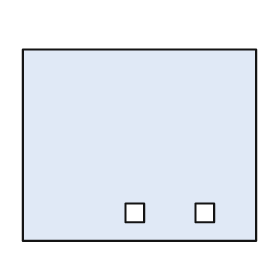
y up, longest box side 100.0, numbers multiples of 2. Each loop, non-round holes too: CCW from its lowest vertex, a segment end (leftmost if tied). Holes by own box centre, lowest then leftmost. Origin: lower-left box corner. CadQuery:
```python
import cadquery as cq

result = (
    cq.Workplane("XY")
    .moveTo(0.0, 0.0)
    .lineTo(100.0, 0.0)
    .lineTo(100.0, 82.0)
    .lineTo(0.0, 82.0)
    .close()
    .moveTo(44.0, 8.0)
    .lineTo(52.0, 8.0)
    .lineTo(52.0, 16.0)
    .lineTo(44.0, 16.0)
    .close()
    .moveTo(74.0, 8.0)
    .lineTo(82.0, 8.0)
    .lineTo(82.0, 16.0)
    .lineTo(74.0, 16.0)
    .close()
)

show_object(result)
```